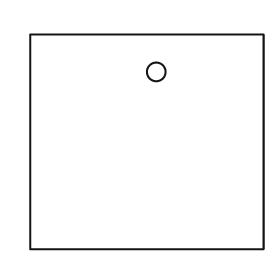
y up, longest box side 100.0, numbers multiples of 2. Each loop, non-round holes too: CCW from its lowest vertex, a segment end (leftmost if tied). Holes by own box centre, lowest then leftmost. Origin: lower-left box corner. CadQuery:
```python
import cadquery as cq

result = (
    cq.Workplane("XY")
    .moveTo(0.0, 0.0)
    .lineTo(100.0, 0.0)
    .lineTo(100.0, 92.0)
    .lineTo(0.0, 92.0)
    .close()
    .moveTo(54.0, 76.0)
    .circle(4.0)
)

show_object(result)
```